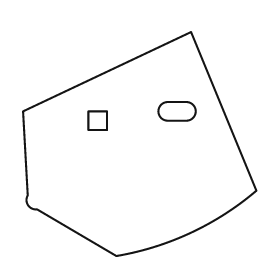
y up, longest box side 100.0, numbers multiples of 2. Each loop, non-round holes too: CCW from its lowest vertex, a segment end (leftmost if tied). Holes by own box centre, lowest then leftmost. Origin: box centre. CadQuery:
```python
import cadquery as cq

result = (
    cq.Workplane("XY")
    .moveTo(-10.0, -48.0)
    .threePointArc((22.0, -38.0), (50.0, -20.0))
    .lineTo(22.0, 48.0)
    .lineTo(-50.0, 14.0)
    .lineTo(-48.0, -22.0)
    .threePointArc((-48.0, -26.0), (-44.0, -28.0))
    .close()
    .moveTo(-22.0, 6.0)
    .lineTo(-14.0, 6.0)
    .lineTo(-14.0, 14.0)
    .lineTo(-22.0, 14.0)
    .close()
    .moveTo(12.0, 10.0)
    .lineTo(20.0, 10.0)
    .threePointArc((24.0, 14.0), (20.0, 18.0))
    .lineTo(12.0, 18.0)
    .threePointArc((8.0, 14.0), (12.0, 10.0))
    .close()
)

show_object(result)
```